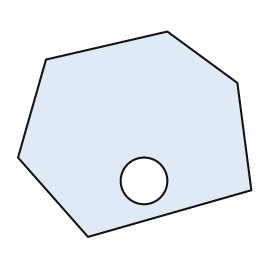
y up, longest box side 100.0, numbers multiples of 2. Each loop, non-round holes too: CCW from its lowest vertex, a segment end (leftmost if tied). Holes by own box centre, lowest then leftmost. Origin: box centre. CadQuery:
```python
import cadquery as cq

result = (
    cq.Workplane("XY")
    .moveTo(-20.0, -44.0)
    .lineTo(50.0, -24.0)
    .lineTo(44.0, 22.0)
    .lineTo(14.0, 44.0)
    .lineTo(-38.0, 32.0)
    .lineTo(-50.0, -10.0)
    .close()
    .moveTo(4.0, -20.0)
    .circle(10.0)
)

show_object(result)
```